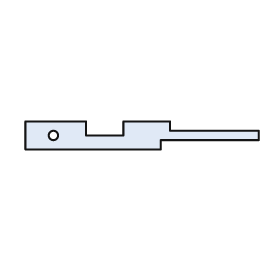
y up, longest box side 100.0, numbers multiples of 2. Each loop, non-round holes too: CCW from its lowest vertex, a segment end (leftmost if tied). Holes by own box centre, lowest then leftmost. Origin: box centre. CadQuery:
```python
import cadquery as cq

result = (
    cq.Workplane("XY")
    .moveTo(-50.0, -6.0)
    .lineTo(8.0, -6.0)
    .lineTo(8.0, -2.0)
    .lineTo(50.0, -2.0)
    .lineTo(50.0, 2.0)
    .lineTo(12.0, 2.0)
    .lineTo(12.0, 6.0)
    .lineTo(-8.0, 6.0)
    .lineTo(-8.0, 0.0)
    .lineTo(-24.0, 0.0)
    .lineTo(-24.0, 6.0)
    .lineTo(-50.0, 6.0)
    .close()
    .moveTo(-38.0, 0.0)
    .circle(2.0)
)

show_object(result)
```